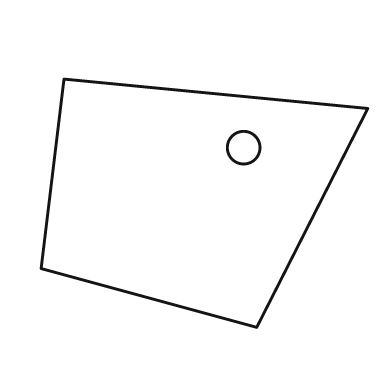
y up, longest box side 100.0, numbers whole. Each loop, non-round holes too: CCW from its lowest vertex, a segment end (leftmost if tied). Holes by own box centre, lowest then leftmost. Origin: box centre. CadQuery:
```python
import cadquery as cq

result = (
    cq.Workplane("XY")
    .moveTo(16.0, -38.0)
    .lineTo(50.0, 29.0)
    .lineTo(-43.0, 38.0)
    .lineTo(-50.0, -20.0)
    .close()
    .moveTo(12.0, 17.0)
    .circle(5.0)
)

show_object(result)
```